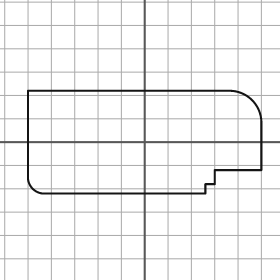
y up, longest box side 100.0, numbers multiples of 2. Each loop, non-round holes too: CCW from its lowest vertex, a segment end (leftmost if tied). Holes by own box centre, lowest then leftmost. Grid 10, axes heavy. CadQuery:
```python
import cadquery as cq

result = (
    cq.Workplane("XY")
    .moveTo(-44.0, -22.0)
    .lineTo(26.0, -22.0)
    .lineTo(26.0, -18.0)
    .lineTo(30.0, -18.0)
    .lineTo(30.0, -12.0)
    .lineTo(50.0, -12.0)
    .lineTo(50.0, 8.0)
    .threePointArc((46.0, 18.0), (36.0, 22.0))
    .lineTo(-50.0, 22.0)
    .lineTo(-50.0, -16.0)
    .threePointArc((-48.0, -20.0), (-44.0, -22.0))
    .close()
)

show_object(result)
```